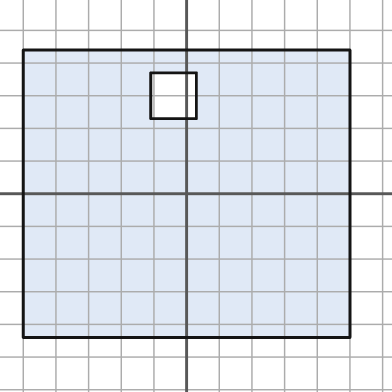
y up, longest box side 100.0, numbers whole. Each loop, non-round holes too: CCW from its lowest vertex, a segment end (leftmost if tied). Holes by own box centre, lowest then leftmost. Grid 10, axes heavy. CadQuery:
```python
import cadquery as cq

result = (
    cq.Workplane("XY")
    .moveTo(-50.0, -44.0)
    .lineTo(50.0, -44.0)
    .lineTo(50.0, 44.0)
    .lineTo(-50.0, 44.0)
    .close()
    .moveTo(-11.0, 23.0)
    .lineTo(3.0, 23.0)
    .lineTo(3.0, 37.0)
    .lineTo(-11.0, 37.0)
    .close()
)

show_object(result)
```